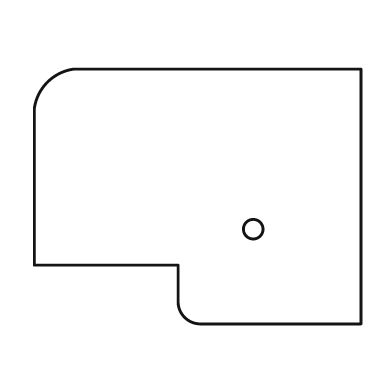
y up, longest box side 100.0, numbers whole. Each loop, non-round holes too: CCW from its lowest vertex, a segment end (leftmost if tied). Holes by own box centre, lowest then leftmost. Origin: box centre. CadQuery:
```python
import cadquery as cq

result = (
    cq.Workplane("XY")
    .moveTo(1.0, -39.0)
    .lineTo(50.0, -39.0)
    .lineTo(50.0, 39.0)
    .lineTo(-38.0, 39.0)
    .threePointArc((-46.0, 35.0), (-50.0, 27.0))
    .lineTo(-50.0, -21.0)
    .lineTo(-6.0, -21.0)
    .lineTo(-6.0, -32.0)
    .threePointArc((-4.0, -37.0), (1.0, -39.0))
    .close()
    .moveTo(17.0, -10.0)
    .circle(3.0)
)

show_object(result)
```